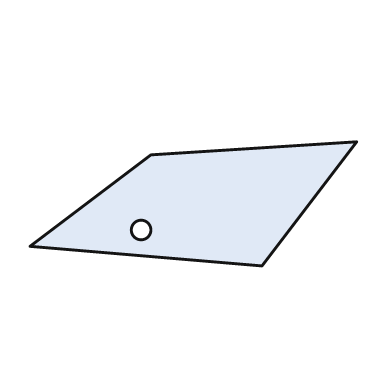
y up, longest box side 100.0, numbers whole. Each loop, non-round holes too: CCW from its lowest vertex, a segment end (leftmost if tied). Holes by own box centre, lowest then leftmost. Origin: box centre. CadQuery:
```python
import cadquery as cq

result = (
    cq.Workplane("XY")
    .moveTo(21.0, -19.0)
    .lineTo(50.0, 19.0)
    .lineTo(-13.0, 15.0)
    .lineTo(-50.0, -13.0)
    .close()
    .moveTo(-16.0, -8.0)
    .circle(3.0)
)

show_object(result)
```